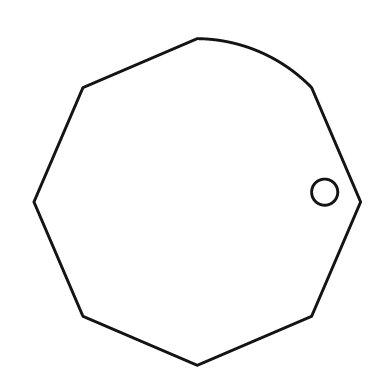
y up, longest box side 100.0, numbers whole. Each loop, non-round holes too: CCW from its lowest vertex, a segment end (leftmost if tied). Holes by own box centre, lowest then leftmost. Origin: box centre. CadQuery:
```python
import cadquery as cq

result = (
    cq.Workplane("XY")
    .moveTo(0.0, -50.0)
    .lineTo(35.0, -35.0)
    .lineTo(50.0, 0.0)
    .lineTo(35.0, 35.0)
    .threePointArc((19.0, 46.0), (0.0, 50.0))
    .lineTo(-35.0, 35.0)
    .lineTo(-50.0, 0.0)
    .lineTo(-35.0, -35.0)
    .close()
    .moveTo(39.0, 3.0)
    .circle(4.0)
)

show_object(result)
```